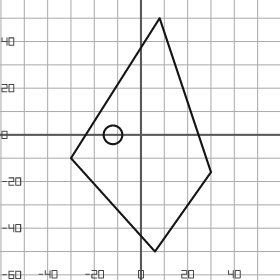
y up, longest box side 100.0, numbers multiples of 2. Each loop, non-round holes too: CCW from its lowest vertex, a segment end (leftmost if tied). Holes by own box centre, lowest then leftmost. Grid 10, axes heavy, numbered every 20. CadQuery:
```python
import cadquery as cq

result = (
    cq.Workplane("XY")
    .moveTo(6.0, -50.0)
    .lineTo(30.0, -16.0)
    .lineTo(8.0, 50.0)
    .lineTo(-30.0, -10.0)
    .close()
    .moveTo(-12.0, 0.0)
    .circle(4.0)
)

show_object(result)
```